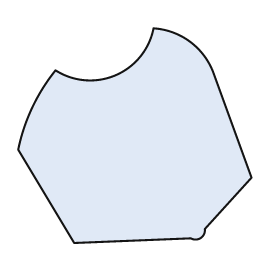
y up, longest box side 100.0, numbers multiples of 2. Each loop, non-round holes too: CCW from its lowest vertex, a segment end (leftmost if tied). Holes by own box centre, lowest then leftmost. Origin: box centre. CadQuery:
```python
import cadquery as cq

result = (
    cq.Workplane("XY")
    .moveTo(-26.0, -46.0)
    .lineTo(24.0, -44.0)
    .threePointArc((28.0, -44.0), (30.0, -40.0))
    .lineTo(50.0, -18.0)
    .lineTo(34.0, 26.0)
    .threePointArc((24.0, 40.0), (8.0, 46.0))
    .threePointArc((-8.0, 26.0), (-34.0, 28.0))
    .threePointArc((-44.0, 12.0), (-50.0, -6.0))
    .close()
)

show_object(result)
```